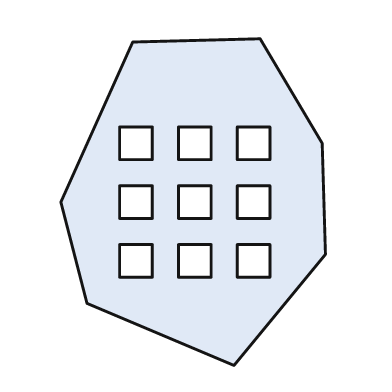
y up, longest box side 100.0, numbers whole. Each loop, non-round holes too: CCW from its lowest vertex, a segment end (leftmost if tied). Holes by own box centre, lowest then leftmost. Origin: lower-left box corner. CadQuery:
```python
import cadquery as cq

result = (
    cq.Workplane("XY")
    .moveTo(53.0, 0.0)
    .lineTo(81.0, 34.0)
    .lineTo(80.0, 68.0)
    .lineTo(61.0, 100.0)
    .lineTo(22.0, 99.0)
    .lineTo(0.0, 50.0)
    .lineTo(8.0, 19.0)
    .close()
    .moveTo(18.0, 27.0)
    .lineTo(28.0, 27.0)
    .lineTo(28.0, 37.0)
    .lineTo(18.0, 37.0)
    .close()
    .moveTo(36.0, 27.0)
    .lineTo(46.0, 27.0)
    .lineTo(46.0, 37.0)
    .lineTo(36.0, 37.0)
    .close()
    .moveTo(54.0, 27.0)
    .lineTo(64.0, 27.0)
    .lineTo(64.0, 37.0)
    .lineTo(54.0, 37.0)
    .close()
    .moveTo(18.0, 45.0)
    .lineTo(28.0, 45.0)
    .lineTo(28.0, 55.0)
    .lineTo(18.0, 55.0)
    .close()
    .moveTo(36.0, 45.0)
    .lineTo(46.0, 45.0)
    .lineTo(46.0, 55.0)
    .lineTo(36.0, 55.0)
    .close()
    .moveTo(54.0, 45.0)
    .lineTo(64.0, 45.0)
    .lineTo(64.0, 55.0)
    .lineTo(54.0, 55.0)
    .close()
    .moveTo(18.0, 63.0)
    .lineTo(28.0, 63.0)
    .lineTo(28.0, 73.0)
    .lineTo(18.0, 73.0)
    .close()
    .moveTo(36.0, 63.0)
    .lineTo(46.0, 63.0)
    .lineTo(46.0, 73.0)
    .lineTo(36.0, 73.0)
    .close()
    .moveTo(54.0, 63.0)
    .lineTo(64.0, 63.0)
    .lineTo(64.0, 73.0)
    .lineTo(54.0, 73.0)
    .close()
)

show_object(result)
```